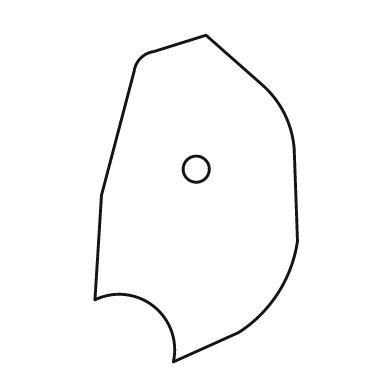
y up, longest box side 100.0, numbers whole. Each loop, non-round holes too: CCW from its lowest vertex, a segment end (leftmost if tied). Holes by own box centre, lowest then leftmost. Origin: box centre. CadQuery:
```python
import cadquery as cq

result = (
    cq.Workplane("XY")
    .moveTo(-7.0, -50.0)
    .lineTo(13.0, -41.0)
    .threePointArc((25.0, -29.0), (31.0, -13.0))
    .lineTo(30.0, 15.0)
    .threePointArc((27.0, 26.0), (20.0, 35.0))
    .lineTo(3.0, 50.0)
    .lineTo(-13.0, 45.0)
    .threePointArc((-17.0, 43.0), (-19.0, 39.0))
    .lineTo(-29.0, 1.0)
    .lineTo(-31.0, -31.0)
    .threePointArc((-13.0, -33.0), (-7.0, -50.0))
    .close()
    .moveTo(0.0, 9.0)
    .circle(4.0)
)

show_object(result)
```